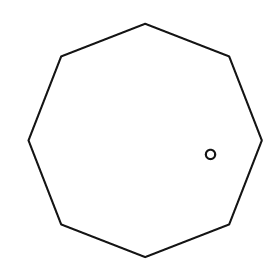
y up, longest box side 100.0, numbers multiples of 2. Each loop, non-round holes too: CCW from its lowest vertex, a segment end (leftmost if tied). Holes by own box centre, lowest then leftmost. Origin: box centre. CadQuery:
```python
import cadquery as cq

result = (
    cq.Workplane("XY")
    .moveTo(0.0, -50.0)
    .lineTo(36.0, -36.0)
    .lineTo(50.0, 0.0)
    .lineTo(36.0, 36.0)
    .lineTo(0.0, 50.0)
    .lineTo(-36.0, 36.0)
    .lineTo(-50.0, 0.0)
    .lineTo(-36.0, -36.0)
    .close()
    .moveTo(28.0, -6.0)
    .circle(2.0)
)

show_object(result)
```